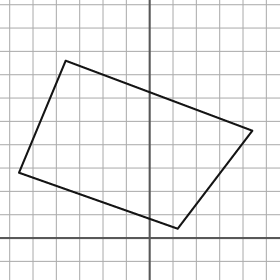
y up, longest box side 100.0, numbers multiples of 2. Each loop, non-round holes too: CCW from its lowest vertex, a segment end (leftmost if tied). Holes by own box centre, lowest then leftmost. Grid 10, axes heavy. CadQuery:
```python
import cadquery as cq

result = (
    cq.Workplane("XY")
    .moveTo(12.0, 4.0)
    .lineTo(44.0, 46.0)
    .lineTo(-36.0, 76.0)
    .lineTo(-56.0, 28.0)
    .close()
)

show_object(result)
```